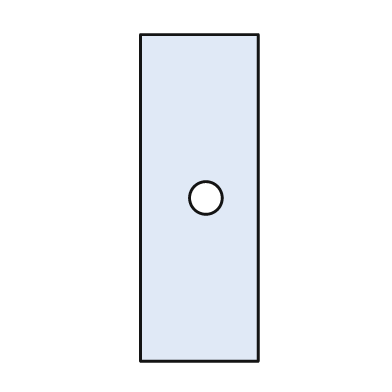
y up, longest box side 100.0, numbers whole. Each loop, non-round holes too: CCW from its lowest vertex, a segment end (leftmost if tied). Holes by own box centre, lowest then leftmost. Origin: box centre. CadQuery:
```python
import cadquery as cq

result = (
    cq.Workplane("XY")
    .moveTo(-18.0, -50.0)
    .lineTo(18.0, -50.0)
    .lineTo(18.0, 50.0)
    .lineTo(-18.0, 50.0)
    .close()
    .moveTo(2.0, 0.0)
    .circle(5.0)
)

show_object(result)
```